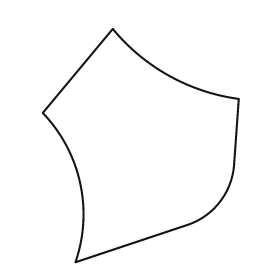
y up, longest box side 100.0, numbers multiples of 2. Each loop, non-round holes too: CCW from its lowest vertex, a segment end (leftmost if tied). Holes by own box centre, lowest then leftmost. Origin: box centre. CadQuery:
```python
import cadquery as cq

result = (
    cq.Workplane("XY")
    .moveTo(-28.0, -50.0)
    .lineTo(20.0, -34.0)
    .threePointArc((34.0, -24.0), (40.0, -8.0))
    .lineTo(42.0, 20.0)
    .threePointArc((12.0, 30.0), (-12.0, 50.0))
    .lineTo(-42.0, 14.0)
    .threePointArc((-26.0, -16.0), (-28.0, -50.0))
    .close()
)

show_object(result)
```